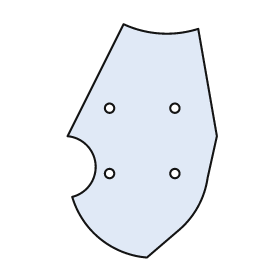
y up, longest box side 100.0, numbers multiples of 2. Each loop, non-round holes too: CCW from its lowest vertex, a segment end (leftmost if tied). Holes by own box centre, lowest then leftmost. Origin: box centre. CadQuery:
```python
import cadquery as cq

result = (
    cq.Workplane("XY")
    .moveTo(2.0, -50.0)
    .lineTo(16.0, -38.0)
    .threePointArc((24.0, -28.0), (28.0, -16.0))
    .lineTo(32.0, 2.0)
    .lineTo(24.0, 48.0)
    .threePointArc((8.0, 46.0), (-8.0, 50.0))
    .lineTo(-32.0, 2.0)
    .threePointArc((-20.0, -10.0), (-30.0, -24.0))
    .threePointArc((-18.0, -42.0), (2.0, -50.0))
    .close()
    .moveTo(-14.0, -14.0)
    .circle(2.0)
    .moveTo(14.0, -14.0)
    .circle(2.0)
    .moveTo(-14.0, 14.0)
    .circle(2.0)
    .moveTo(14.0, 14.0)
    .circle(2.0)
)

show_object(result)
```